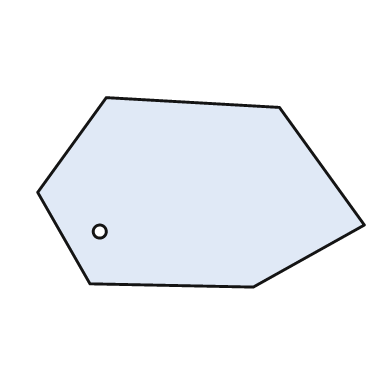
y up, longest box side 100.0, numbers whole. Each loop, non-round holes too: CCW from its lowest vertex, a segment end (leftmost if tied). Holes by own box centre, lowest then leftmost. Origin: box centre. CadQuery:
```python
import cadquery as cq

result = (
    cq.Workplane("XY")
    .moveTo(16.0, -29.0)
    .lineTo(50.0, -10.0)
    .lineTo(24.0, 26.0)
    .lineTo(-29.0, 29.0)
    .lineTo(-50.0, 0.0)
    .lineTo(-34.0, -28.0)
    .close()
    .moveTo(-31.0, -12.0)
    .circle(2.0)
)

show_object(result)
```